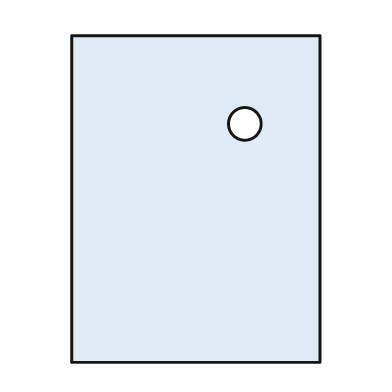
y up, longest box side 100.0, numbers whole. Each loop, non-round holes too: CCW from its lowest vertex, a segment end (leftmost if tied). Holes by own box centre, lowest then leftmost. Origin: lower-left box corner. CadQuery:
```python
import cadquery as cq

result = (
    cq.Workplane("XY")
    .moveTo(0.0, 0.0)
    .lineTo(76.0, 0.0)
    .lineTo(76.0, 100.0)
    .lineTo(0.0, 100.0)
    .close()
    .moveTo(53.0, 73.0)
    .circle(5.0)
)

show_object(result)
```